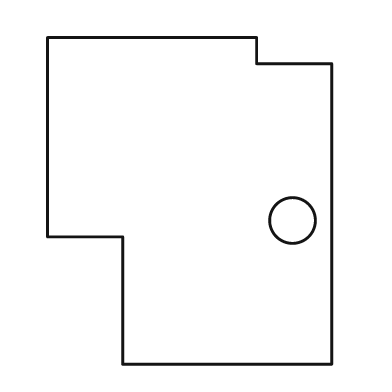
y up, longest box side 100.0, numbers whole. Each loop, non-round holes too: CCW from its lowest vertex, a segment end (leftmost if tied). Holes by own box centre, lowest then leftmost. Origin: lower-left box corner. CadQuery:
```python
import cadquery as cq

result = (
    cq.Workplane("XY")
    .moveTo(23.0, 0.0)
    .lineTo(87.0, 0.0)
    .lineTo(87.0, 92.0)
    .lineTo(64.0, 92.0)
    .lineTo(64.0, 100.0)
    .lineTo(0.0, 100.0)
    .lineTo(0.0, 39.0)
    .lineTo(23.0, 39.0)
    .close()
    .moveTo(75.0, 44.0)
    .circle(7.0)
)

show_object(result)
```